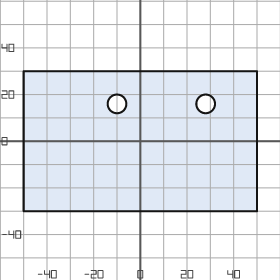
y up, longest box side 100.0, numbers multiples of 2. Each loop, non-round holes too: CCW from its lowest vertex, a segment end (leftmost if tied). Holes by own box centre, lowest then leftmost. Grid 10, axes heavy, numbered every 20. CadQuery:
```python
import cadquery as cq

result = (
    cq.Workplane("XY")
    .moveTo(-50.0, -30.0)
    .lineTo(50.0, -30.0)
    .lineTo(50.0, 30.0)
    .lineTo(-50.0, 30.0)
    .close()
    .moveTo(-10.0, 16.0)
    .circle(4.0)
    .moveTo(28.0, 16.0)
    .circle(4.0)
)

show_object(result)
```